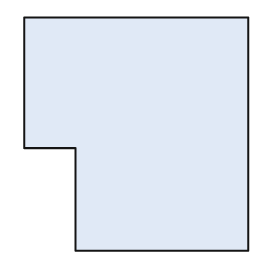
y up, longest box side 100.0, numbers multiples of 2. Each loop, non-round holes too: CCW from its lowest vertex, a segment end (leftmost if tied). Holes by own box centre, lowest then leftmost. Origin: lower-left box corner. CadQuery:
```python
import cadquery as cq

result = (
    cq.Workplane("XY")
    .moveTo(22.0, 0.0)
    .lineTo(96.0, 0.0)
    .lineTo(96.0, 100.0)
    .lineTo(0.0, 100.0)
    .lineTo(0.0, 44.0)
    .lineTo(22.0, 44.0)
    .close()
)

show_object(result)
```